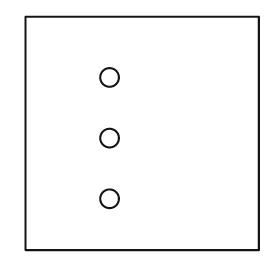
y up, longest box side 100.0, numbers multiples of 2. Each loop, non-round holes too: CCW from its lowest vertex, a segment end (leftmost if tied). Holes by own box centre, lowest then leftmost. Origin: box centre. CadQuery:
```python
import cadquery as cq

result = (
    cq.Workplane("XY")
    .moveTo(-50.0, -50.0)
    .lineTo(50.0, -50.0)
    .lineTo(50.0, 50.0)
    .lineTo(-50.0, 50.0)
    .close()
    .moveTo(-14.0, -28.0)
    .circle(4.0)
    .moveTo(-14.0, -2.0)
    .circle(4.0)
    .moveTo(-14.0, 24.0)
    .circle(4.0)
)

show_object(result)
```